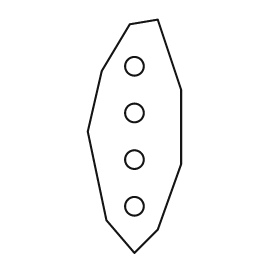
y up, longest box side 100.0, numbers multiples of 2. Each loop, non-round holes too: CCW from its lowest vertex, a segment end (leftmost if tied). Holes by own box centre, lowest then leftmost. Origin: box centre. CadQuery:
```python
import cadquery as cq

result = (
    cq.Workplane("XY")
    .moveTo(0.0, -50.0)
    .lineTo(10.0, -40.0)
    .lineTo(20.0, -12.0)
    .lineTo(20.0, 20.0)
    .lineTo(10.0, 50.0)
    .lineTo(-2.0, 48.0)
    .lineTo(-14.0, 28.0)
    .lineTo(-20.0, 2.0)
    .lineTo(-12.0, -36.0)
    .close()
    .moveTo(0.0, -30.0)
    .circle(4.0)
    .moveTo(0.0, -10.0)
    .circle(4.0)
    .moveTo(0.0, 10.0)
    .circle(4.0)
    .moveTo(0.0, 30.0)
    .circle(4.0)
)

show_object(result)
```